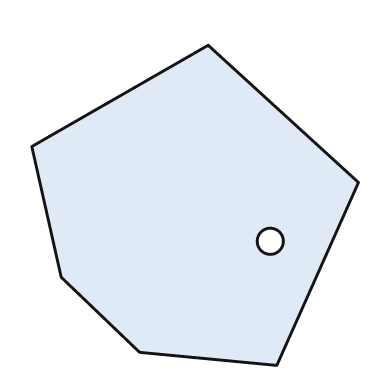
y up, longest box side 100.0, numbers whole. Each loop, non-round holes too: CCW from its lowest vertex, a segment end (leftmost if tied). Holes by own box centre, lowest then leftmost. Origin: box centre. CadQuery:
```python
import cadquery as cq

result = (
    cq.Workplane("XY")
    .moveTo(25.0, -49.0)
    .lineTo(50.0, 7.0)
    .lineTo(4.0, 49.0)
    .lineTo(-50.0, 18.0)
    .lineTo(-41.0, -22.0)
    .lineTo(-17.0, -45.0)
    .close()
    .moveTo(23.0, -11.0)
    .circle(4.0)
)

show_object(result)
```